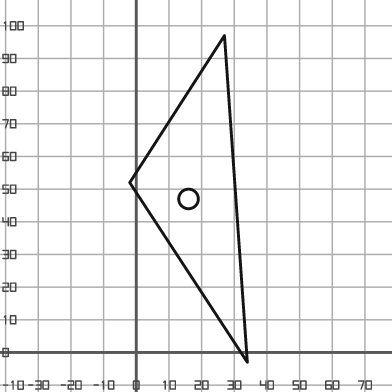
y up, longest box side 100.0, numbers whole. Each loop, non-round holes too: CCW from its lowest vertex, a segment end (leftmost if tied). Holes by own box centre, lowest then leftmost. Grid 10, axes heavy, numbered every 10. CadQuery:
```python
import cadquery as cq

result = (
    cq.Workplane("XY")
    .moveTo(34.0, -3.0)
    .lineTo(27.0, 97.0)
    .lineTo(-2.0, 52.0)
    .close()
    .moveTo(16.0, 47.0)
    .circle(3.0)
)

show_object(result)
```